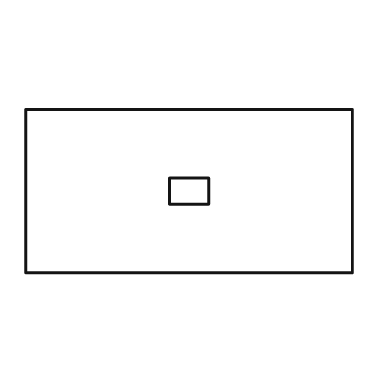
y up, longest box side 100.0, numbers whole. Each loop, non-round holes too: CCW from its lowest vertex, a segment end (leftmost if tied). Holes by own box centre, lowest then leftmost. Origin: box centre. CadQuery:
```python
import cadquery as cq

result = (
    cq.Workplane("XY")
    .moveTo(-50.0, -25.0)
    .lineTo(50.0, -25.0)
    .lineTo(50.0, 25.0)
    .lineTo(-50.0, 25.0)
    .close()
    .moveTo(-6.0, -4.0)
    .lineTo(6.0, -4.0)
    .lineTo(6.0, 4.0)
    .lineTo(-6.0, 4.0)
    .close()
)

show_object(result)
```